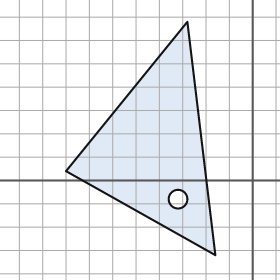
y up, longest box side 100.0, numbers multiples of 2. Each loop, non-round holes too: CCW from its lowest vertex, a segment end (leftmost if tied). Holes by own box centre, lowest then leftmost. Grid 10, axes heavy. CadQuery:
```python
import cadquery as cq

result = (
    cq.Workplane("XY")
    .moveTo(-16.0, -32.0)
    .lineTo(-28.0, 68.0)
    .lineTo(-80.0, 4.0)
    .close()
    .moveTo(-32.0, -8.0)
    .circle(4.0)
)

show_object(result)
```